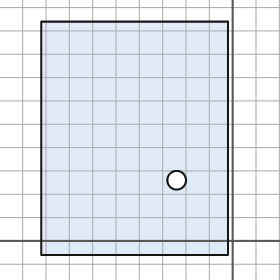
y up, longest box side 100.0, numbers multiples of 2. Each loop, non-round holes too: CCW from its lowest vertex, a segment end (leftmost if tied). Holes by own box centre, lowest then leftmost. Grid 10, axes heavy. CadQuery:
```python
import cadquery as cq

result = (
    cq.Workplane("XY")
    .moveTo(-82.0, -6.0)
    .lineTo(-2.0, -6.0)
    .lineTo(-2.0, 94.0)
    .lineTo(-82.0, 94.0)
    .close()
    .moveTo(-24.0, 26.0)
    .circle(4.0)
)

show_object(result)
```